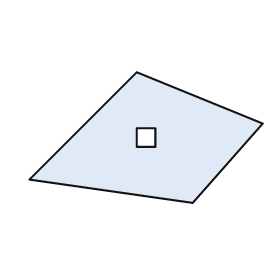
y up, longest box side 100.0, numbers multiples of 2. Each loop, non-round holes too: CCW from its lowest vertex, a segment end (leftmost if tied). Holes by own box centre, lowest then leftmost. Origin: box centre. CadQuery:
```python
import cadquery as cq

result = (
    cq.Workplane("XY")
    .moveTo(20.0, -28.0)
    .lineTo(50.0, 6.0)
    .lineTo(-4.0, 28.0)
    .lineTo(-50.0, -18.0)
    .close()
    .moveTo(-4.0, -4.0)
    .lineTo(4.0, -4.0)
    .lineTo(4.0, 4.0)
    .lineTo(-4.0, 4.0)
    .close()
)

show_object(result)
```